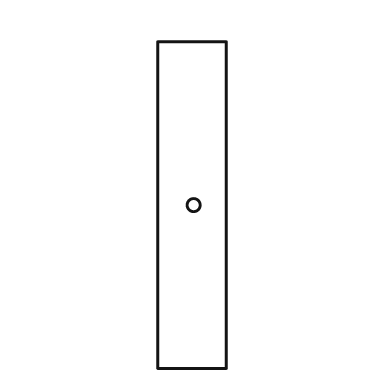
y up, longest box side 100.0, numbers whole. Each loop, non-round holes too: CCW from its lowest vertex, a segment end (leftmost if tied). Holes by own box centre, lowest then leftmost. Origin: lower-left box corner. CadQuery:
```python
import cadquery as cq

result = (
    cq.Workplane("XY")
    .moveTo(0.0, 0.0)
    .lineTo(21.0, 0.0)
    .lineTo(21.0, 100.0)
    .lineTo(0.0, 100.0)
    .close()
    .moveTo(11.0, 50.0)
    .circle(2.0)
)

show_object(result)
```